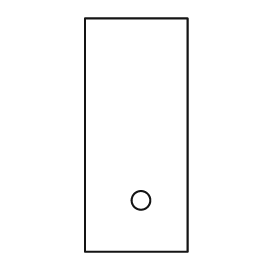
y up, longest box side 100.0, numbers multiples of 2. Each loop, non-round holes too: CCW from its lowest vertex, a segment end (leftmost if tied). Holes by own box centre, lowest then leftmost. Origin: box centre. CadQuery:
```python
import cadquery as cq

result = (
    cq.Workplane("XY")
    .moveTo(-22.0, -50.0)
    .lineTo(22.0, -50.0)
    .lineTo(22.0, 50.0)
    .lineTo(-22.0, 50.0)
    .close()
    .moveTo(2.0, -28.0)
    .circle(4.0)
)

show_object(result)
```